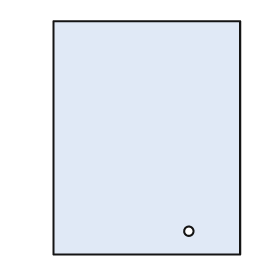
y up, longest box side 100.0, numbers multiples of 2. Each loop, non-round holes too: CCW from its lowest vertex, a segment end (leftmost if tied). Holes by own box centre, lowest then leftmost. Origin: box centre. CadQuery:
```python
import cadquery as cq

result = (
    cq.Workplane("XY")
    .moveTo(-40.0, -50.0)
    .lineTo(40.0, -50.0)
    .lineTo(40.0, 50.0)
    .lineTo(-40.0, 50.0)
    .close()
    .moveTo(18.0, -40.0)
    .circle(2.0)
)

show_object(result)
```